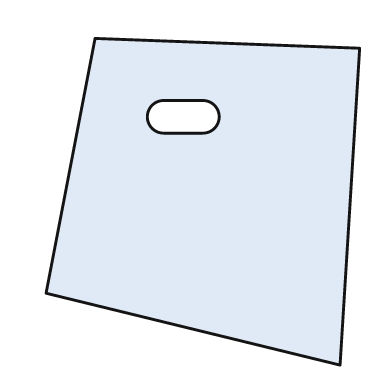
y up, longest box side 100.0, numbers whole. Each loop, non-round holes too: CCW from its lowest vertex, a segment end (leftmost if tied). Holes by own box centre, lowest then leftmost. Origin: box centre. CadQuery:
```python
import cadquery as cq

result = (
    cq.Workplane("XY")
    .moveTo(42.0, -50.0)
    .lineTo(48.0, 47.0)
    .lineTo(-33.0, 50.0)
    .lineTo(-48.0, -28.0)
    .close()
    .moveTo(-12.0, 21.0)
    .lineTo(0.0, 21.0)
    .threePointArc((5.0, 26.0), (0.0, 31.0))
    .lineTo(-12.0, 31.0)
    .threePointArc((-17.0, 26.0), (-12.0, 21.0))
    .close()
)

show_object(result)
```